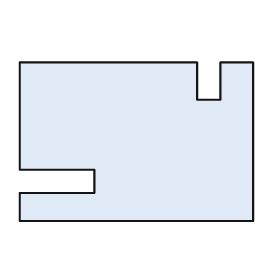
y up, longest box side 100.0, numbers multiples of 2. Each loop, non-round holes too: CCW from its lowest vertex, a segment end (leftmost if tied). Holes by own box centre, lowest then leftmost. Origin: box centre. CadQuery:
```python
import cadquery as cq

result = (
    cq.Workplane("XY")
    .moveTo(-50.0, -34.0)
    .lineTo(50.0, -34.0)
    .lineTo(50.0, 34.0)
    .lineTo(36.0, 34.0)
    .lineTo(36.0, 18.0)
    .lineTo(26.0, 18.0)
    .lineTo(26.0, 34.0)
    .lineTo(-50.0, 34.0)
    .lineTo(-50.0, -12.0)
    .lineTo(-18.0, -12.0)
    .lineTo(-18.0, -22.0)
    .lineTo(-50.0, -22.0)
    .close()
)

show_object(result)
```